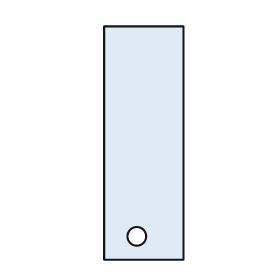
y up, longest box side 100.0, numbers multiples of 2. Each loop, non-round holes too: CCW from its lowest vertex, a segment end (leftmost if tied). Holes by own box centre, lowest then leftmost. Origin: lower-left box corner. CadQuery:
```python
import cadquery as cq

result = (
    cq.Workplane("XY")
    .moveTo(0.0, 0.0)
    .lineTo(34.0, 0.0)
    .lineTo(34.0, 100.0)
    .lineTo(0.0, 100.0)
    .close()
    .moveTo(14.0, 10.0)
    .circle(4.0)
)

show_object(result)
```